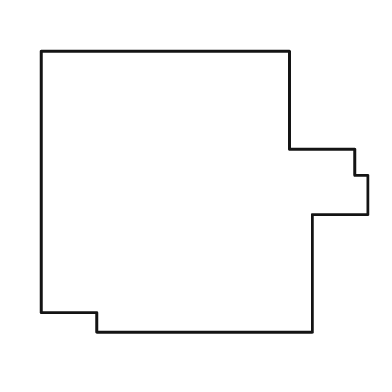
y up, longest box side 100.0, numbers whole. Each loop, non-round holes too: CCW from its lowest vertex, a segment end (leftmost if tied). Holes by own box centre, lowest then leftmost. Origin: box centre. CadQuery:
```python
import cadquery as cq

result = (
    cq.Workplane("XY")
    .moveTo(-33.0, -43.0)
    .lineTo(33.0, -43.0)
    .lineTo(33.0, -7.0)
    .lineTo(50.0, -7.0)
    .lineTo(50.0, 5.0)
    .lineTo(46.0, 5.0)
    .lineTo(46.0, 13.0)
    .lineTo(26.0, 13.0)
    .lineTo(26.0, 43.0)
    .lineTo(-50.0, 43.0)
    .lineTo(-50.0, -37.0)
    .lineTo(-33.0, -37.0)
    .close()
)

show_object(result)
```